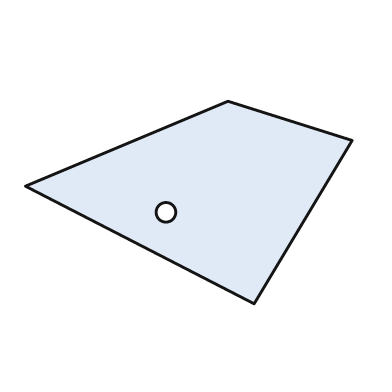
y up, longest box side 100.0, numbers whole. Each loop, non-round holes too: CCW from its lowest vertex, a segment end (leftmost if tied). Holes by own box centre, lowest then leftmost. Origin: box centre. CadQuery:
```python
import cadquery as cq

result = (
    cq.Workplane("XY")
    .moveTo(20.0, -31.0)
    .lineTo(50.0, 19.0)
    .lineTo(12.0, 31.0)
    .lineTo(-50.0, 5.0)
    .close()
    .moveTo(-7.0, -3.0)
    .circle(3.0)
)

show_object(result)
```